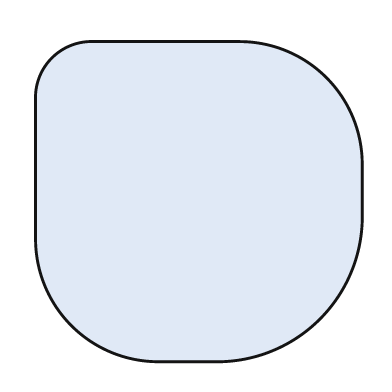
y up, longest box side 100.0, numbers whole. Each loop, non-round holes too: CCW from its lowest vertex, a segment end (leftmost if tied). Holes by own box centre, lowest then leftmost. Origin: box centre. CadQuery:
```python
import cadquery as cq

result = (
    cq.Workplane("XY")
    .moveTo(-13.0, -49.0)
    .lineTo(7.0, -49.0)
    .threePointArc((37.0, -36.0), (50.0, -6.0))
    .lineTo(50.0, 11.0)
    .threePointArc((39.0, 38.0), (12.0, 49.0))
    .lineTo(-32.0, 49.0)
    .threePointArc((-45.0, 44.0), (-50.0, 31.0))
    .lineTo(-50.0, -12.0)
    .threePointArc((-39.0, -38.0), (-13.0, -49.0))
    .close()
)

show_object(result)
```